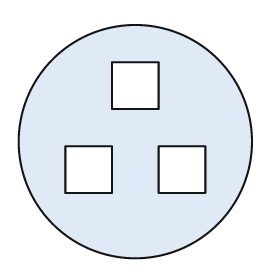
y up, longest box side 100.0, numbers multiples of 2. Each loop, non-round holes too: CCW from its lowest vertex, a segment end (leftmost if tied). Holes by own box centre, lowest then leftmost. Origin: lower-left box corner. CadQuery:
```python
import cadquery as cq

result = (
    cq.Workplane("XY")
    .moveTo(50.0, 50.0)
    .circle(50.0)
    .moveTo(20.0, 28.0)
    .lineTo(40.0, 28.0)
    .lineTo(40.0, 48.0)
    .lineTo(20.0, 48.0)
    .close()
    .moveTo(60.0, 28.0)
    .lineTo(80.0, 28.0)
    .lineTo(80.0, 48.0)
    .lineTo(60.0, 48.0)
    .close()
    .moveTo(40.0, 64.0)
    .lineTo(60.0, 64.0)
    .lineTo(60.0, 84.0)
    .lineTo(40.0, 84.0)
    .close()
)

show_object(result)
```